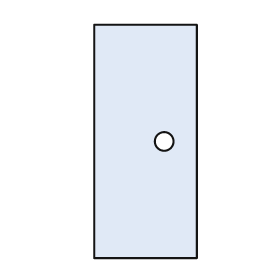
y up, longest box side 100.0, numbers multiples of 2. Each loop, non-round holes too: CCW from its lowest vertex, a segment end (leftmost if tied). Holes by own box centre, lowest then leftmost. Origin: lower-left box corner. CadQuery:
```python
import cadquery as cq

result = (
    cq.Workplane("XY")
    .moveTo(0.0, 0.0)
    .lineTo(44.0, 0.0)
    .lineTo(44.0, 100.0)
    .lineTo(0.0, 100.0)
    .close()
    .moveTo(30.0, 50.0)
    .circle(4.0)
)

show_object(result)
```